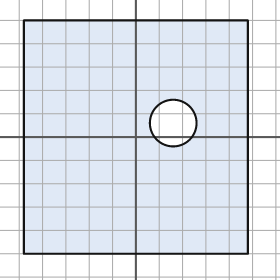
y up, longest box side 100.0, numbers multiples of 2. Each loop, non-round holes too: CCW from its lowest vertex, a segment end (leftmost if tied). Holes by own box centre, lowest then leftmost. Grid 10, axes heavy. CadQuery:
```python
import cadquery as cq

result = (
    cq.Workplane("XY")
    .moveTo(-48.0, -50.0)
    .lineTo(48.0, -50.0)
    .lineTo(48.0, 50.0)
    .lineTo(-48.0, 50.0)
    .close()
    .moveTo(16.0, 6.0)
    .circle(10.0)
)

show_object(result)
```